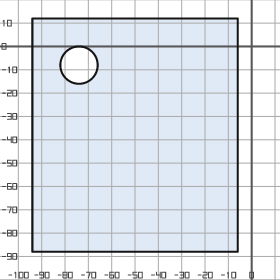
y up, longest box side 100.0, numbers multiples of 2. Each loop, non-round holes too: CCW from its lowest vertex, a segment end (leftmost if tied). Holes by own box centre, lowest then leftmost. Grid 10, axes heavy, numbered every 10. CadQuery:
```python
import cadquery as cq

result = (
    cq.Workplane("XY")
    .moveTo(-94.0, -88.0)
    .lineTo(-6.0, -88.0)
    .lineTo(-6.0, 12.0)
    .lineTo(-94.0, 12.0)
    .close()
    .moveTo(-74.0, -8.0)
    .circle(8.0)
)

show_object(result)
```